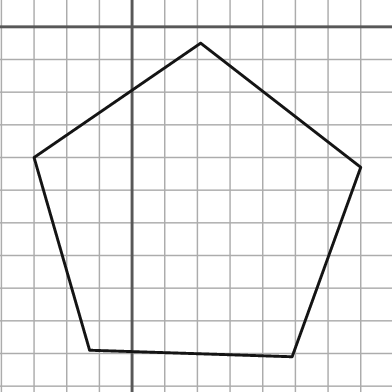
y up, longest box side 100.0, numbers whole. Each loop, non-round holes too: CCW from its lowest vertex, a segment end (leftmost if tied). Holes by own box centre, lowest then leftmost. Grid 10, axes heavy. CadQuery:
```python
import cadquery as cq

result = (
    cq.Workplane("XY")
    .moveTo(49.0, -101.0)
    .lineTo(70.0, -43.0)
    .lineTo(21.0, -5.0)
    .lineTo(-30.0, -40.0)
    .lineTo(-13.0, -99.0)
    .close()
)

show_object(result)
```